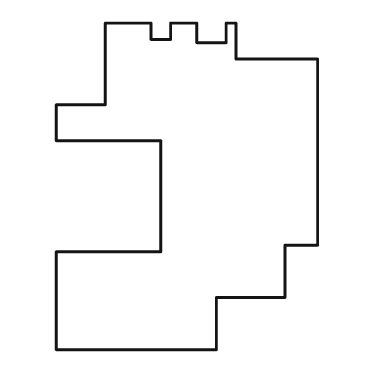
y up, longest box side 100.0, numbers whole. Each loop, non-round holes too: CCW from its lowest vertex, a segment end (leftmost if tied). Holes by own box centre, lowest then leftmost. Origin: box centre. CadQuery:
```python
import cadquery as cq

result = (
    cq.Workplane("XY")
    .moveTo(-40.0, -50.0)
    .lineTo(9.0, -50.0)
    .lineTo(9.0, -34.0)
    .lineTo(30.0, -34.0)
    .lineTo(30.0, -18.0)
    .lineTo(40.0, -18.0)
    .lineTo(40.0, 39.0)
    .lineTo(15.0, 39.0)
    .lineTo(15.0, 50.0)
    .lineTo(12.0, 50.0)
    .lineTo(12.0, 44.0)
    .lineTo(3.0, 44.0)
    .lineTo(3.0, 50.0)
    .lineTo(-5.0, 50.0)
    .lineTo(-5.0, 45.0)
    .lineTo(-11.0, 45.0)
    .lineTo(-11.0, 50.0)
    .lineTo(-25.0, 50.0)
    .lineTo(-25.0, 25.0)
    .lineTo(-40.0, 25.0)
    .lineTo(-40.0, 14.0)
    .lineTo(-8.0, 14.0)
    .lineTo(-8.0, -20.0)
    .lineTo(-40.0, -20.0)
    .close()
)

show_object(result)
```